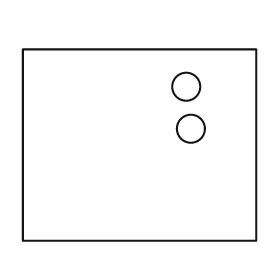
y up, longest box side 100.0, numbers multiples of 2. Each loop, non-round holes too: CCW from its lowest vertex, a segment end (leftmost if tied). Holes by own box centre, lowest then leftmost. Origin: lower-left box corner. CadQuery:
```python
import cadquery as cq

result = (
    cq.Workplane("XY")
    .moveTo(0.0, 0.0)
    .lineTo(100.0, 0.0)
    .lineTo(100.0, 82.0)
    .lineTo(0.0, 82.0)
    .close()
    .moveTo(72.0, 48.0)
    .circle(6.0)
    .moveTo(70.0, 66.0)
    .circle(6.0)
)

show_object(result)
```